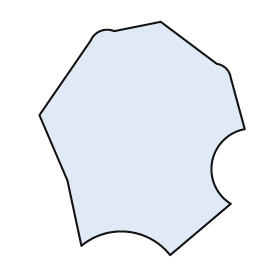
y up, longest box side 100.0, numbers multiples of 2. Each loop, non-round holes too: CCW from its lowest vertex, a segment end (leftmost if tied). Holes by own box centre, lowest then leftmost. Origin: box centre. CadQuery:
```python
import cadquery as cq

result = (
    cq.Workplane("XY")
    .moveTo(12.0, -50.0)
    .lineTo(38.0, -28.0)
    .threePointArc((30.0, -10.0), (44.0, 4.0))
    .lineTo(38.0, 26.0)
    .threePointArc((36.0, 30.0), (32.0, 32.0))
    .lineTo(8.0, 50.0)
    .lineTo(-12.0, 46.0)
    .threePointArc((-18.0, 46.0), (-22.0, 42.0))
    .lineTo(-44.0, 10.0)
    .lineTo(-32.0, -18.0)
    .lineTo(-26.0, -46.0)
    .threePointArc((-6.0, -40.0), (12.0, -50.0))
    .close()
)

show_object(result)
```